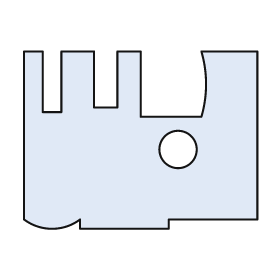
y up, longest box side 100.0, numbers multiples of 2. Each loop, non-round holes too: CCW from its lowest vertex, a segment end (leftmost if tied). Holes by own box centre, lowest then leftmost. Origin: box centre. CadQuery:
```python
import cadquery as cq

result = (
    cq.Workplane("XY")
    .moveTo(-26.0, -38.0)
    .lineTo(12.0, -38.0)
    .lineTo(12.0, -34.0)
    .lineTo(50.0, -34.0)
    .lineTo(50.0, 38.0)
    .lineTo(26.0, 38.0)
    .threePointArc((28.0, 24.0), (26.0, 10.0))
    .lineTo(0.0, 10.0)
    .lineTo(0.0, 38.0)
    .lineTo(-10.0, 38.0)
    .lineTo(-10.0, 14.0)
    .lineTo(-20.0, 14.0)
    .lineTo(-20.0, 38.0)
    .lineTo(-34.0, 38.0)
    .lineTo(-34.0, 12.0)
    .lineTo(-42.0, 12.0)
    .lineTo(-42.0, 38.0)
    .lineTo(-50.0, 38.0)
    .lineTo(-50.0, -34.0)
    .threePointArc((-38.0, -38.0), (-26.0, -34.0))
    .close()
    .moveTo(16.0, -4.0)
    .circle(8.0)
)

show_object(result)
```